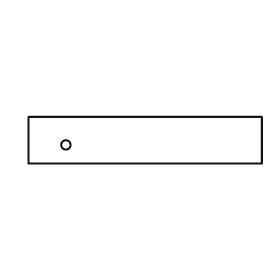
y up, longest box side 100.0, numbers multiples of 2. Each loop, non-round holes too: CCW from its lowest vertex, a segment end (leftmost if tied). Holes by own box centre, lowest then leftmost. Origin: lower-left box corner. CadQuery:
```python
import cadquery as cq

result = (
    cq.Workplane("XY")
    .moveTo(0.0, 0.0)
    .lineTo(100.0, 0.0)
    .lineTo(100.0, 20.0)
    .lineTo(0.0, 20.0)
    .close()
    .moveTo(16.0, 8.0)
    .circle(2.0)
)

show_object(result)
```